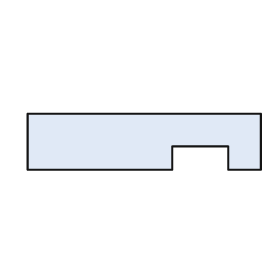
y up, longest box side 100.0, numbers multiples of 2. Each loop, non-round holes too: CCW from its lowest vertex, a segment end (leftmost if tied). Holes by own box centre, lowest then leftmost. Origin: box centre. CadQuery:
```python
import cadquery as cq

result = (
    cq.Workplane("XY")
    .moveTo(-50.0, -12.0)
    .lineTo(12.0, -12.0)
    .lineTo(12.0, -2.0)
    .lineTo(36.0, -2.0)
    .lineTo(36.0, -12.0)
    .lineTo(50.0, -12.0)
    .lineTo(50.0, 12.0)
    .lineTo(-50.0, 12.0)
    .close()
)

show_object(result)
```